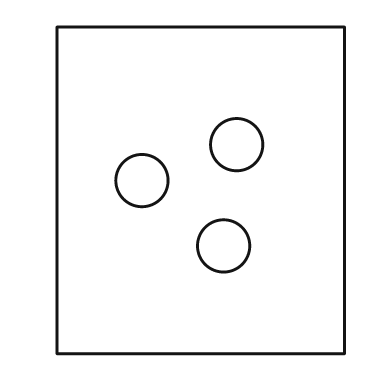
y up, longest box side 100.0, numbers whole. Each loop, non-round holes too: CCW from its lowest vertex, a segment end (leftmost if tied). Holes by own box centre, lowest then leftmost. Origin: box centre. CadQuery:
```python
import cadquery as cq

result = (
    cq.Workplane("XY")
    .moveTo(-44.0, -50.0)
    .lineTo(44.0, -50.0)
    .lineTo(44.0, 50.0)
    .lineTo(-44.0, 50.0)
    .close()
    .moveTo(7.0, -17.0)
    .circle(8.0)
    .moveTo(-18.0, 3.0)
    .circle(8.0)
    .moveTo(11.0, 14.0)
    .circle(8.0)
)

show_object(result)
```